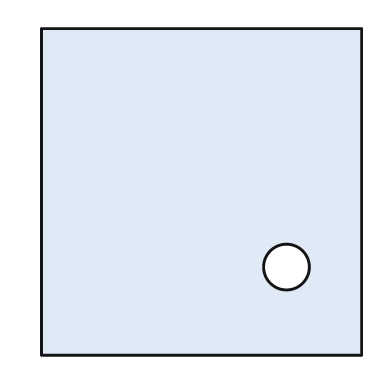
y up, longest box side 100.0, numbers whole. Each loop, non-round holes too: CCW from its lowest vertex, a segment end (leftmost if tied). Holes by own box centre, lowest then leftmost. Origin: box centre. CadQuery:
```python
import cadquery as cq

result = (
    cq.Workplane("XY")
    .moveTo(-49.0, -50.0)
    .lineTo(49.0, -50.0)
    .lineTo(49.0, 50.0)
    .lineTo(-49.0, 50.0)
    .close()
    .moveTo(26.0, -23.0)
    .circle(7.0)
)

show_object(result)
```